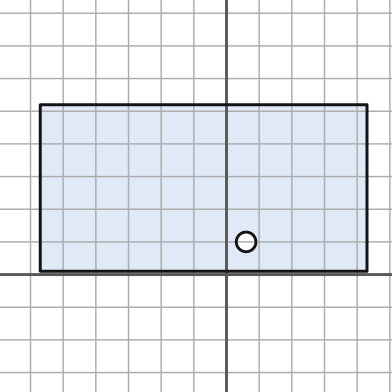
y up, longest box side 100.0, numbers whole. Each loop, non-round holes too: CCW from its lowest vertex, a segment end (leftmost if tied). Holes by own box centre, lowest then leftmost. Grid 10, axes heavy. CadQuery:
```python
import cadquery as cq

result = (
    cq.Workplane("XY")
    .moveTo(-57.0, 1.0)
    .lineTo(43.0, 1.0)
    .lineTo(43.0, 52.0)
    .lineTo(-57.0, 52.0)
    .close()
    .moveTo(6.0, 10.0)
    .circle(3.0)
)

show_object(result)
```